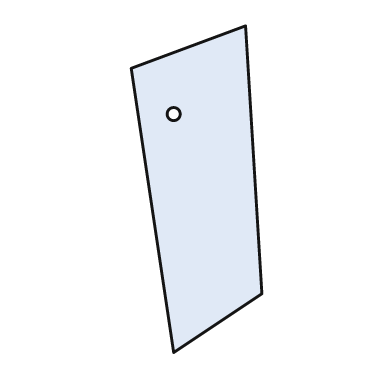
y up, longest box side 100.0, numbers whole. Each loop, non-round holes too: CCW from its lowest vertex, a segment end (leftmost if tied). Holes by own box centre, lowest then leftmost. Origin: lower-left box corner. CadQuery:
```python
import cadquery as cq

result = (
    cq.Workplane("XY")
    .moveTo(13.0, 0.0)
    .lineTo(40.0, 18.0)
    .lineTo(35.0, 100.0)
    .lineTo(0.0, 87.0)
    .close()
    .moveTo(13.0, 73.0)
    .circle(2.0)
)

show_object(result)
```